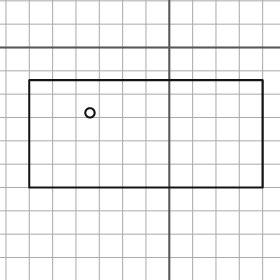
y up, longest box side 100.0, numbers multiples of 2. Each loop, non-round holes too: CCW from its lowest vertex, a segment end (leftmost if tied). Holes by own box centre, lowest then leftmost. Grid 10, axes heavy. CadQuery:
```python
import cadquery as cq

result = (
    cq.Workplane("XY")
    .moveTo(-60.0, -60.0)
    .lineTo(40.0, -60.0)
    .lineTo(40.0, -14.0)
    .lineTo(-60.0, -14.0)
    .close()
    .moveTo(-34.0, -28.0)
    .circle(2.0)
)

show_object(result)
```